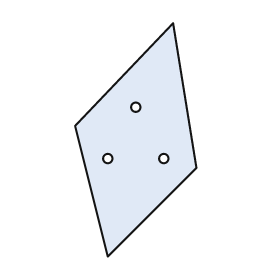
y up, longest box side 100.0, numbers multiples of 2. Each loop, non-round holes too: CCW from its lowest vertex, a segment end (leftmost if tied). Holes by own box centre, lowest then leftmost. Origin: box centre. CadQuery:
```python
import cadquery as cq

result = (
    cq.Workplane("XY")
    .moveTo(-12.0, -50.0)
    .lineTo(26.0, -12.0)
    .lineTo(16.0, 50.0)
    .lineTo(-26.0, 6.0)
    .close()
    .moveTo(-12.0, -8.0)
    .circle(2.0)
    .moveTo(12.0, -8.0)
    .circle(2.0)
    .moveTo(0.0, 14.0)
    .circle(2.0)
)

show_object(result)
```